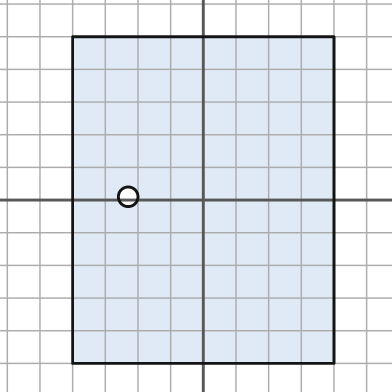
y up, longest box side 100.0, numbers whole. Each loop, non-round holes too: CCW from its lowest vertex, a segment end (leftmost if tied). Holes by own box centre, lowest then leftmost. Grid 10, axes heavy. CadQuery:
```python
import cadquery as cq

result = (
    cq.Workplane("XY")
    .moveTo(-40.0, -50.0)
    .lineTo(40.0, -50.0)
    .lineTo(40.0, 50.0)
    .lineTo(-40.0, 50.0)
    .close()
    .moveTo(-23.0, 1.0)
    .circle(3.0)
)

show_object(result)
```